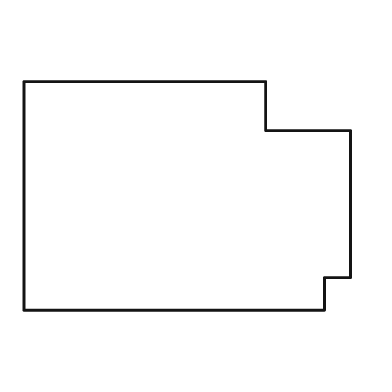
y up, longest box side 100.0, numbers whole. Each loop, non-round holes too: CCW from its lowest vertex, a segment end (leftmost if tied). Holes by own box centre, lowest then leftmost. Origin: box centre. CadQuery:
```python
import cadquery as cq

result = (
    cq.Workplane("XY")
    .moveTo(-50.0, -35.0)
    .lineTo(42.0, -35.0)
    .lineTo(42.0, -25.0)
    .lineTo(50.0, -25.0)
    .lineTo(50.0, 20.0)
    .lineTo(24.0, 20.0)
    .lineTo(24.0, 35.0)
    .lineTo(-50.0, 35.0)
    .close()
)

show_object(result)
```